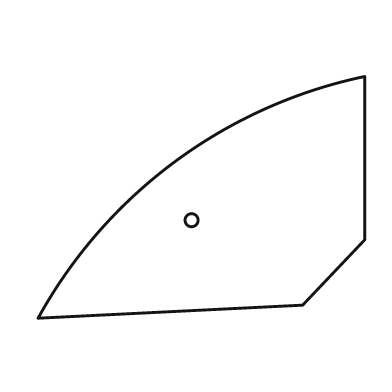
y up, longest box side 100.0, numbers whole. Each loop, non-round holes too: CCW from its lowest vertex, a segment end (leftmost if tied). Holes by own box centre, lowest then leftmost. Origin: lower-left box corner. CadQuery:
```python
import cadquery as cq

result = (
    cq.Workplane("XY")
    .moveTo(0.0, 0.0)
    .lineTo(81.0, 4.0)
    .lineTo(100.0, 24.0)
    .lineTo(100.0, 74.0)
    .threePointArc((42.0, 48.0), (0.0, 0.0))
    .close()
    .moveTo(47.0, 30.0)
    .circle(2.0)
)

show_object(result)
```